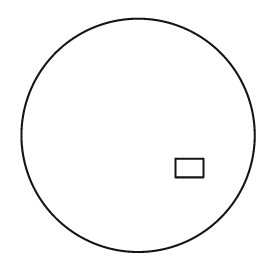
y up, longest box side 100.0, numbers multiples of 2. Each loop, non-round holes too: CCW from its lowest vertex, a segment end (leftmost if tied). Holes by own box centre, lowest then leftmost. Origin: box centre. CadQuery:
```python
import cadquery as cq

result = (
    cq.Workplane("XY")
    .moveTo(0.0, 0.0)
    .circle(50.0)
    .moveTo(16.0, -18.0)
    .lineTo(28.0, -18.0)
    .lineTo(28.0, -10.0)
    .lineTo(16.0, -10.0)
    .close()
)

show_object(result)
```